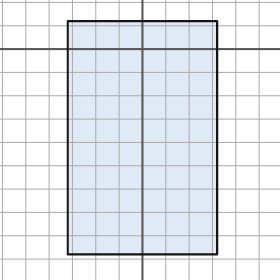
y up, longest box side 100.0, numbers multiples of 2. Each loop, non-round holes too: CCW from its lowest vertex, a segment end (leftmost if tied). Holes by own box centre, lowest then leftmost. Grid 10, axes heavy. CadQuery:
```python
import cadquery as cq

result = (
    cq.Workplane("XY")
    .moveTo(-32.0, -88.0)
    .lineTo(32.0, -88.0)
    .lineTo(32.0, 12.0)
    .lineTo(-32.0, 12.0)
    .close()
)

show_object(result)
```